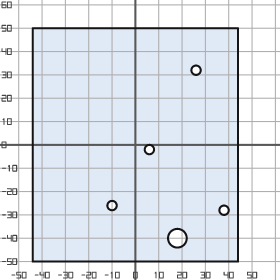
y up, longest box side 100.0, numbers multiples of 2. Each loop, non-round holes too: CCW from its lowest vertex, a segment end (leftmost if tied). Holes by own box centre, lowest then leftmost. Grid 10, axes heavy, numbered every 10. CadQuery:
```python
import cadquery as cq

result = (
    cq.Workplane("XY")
    .moveTo(-44.0, -50.0)
    .lineTo(44.0, -50.0)
    .lineTo(44.0, 50.0)
    .lineTo(-44.0, 50.0)
    .close()
    .moveTo(18.0, -40.0)
    .circle(4.0)
    .moveTo(38.0, -28.0)
    .circle(2.0)
    .moveTo(-10.0, -26.0)
    .circle(2.0)
    .moveTo(6.0, -2.0)
    .circle(2.0)
    .moveTo(26.0, 32.0)
    .circle(2.0)
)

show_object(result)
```